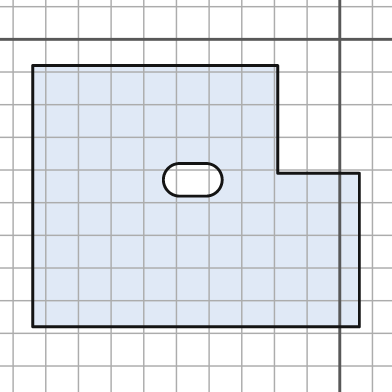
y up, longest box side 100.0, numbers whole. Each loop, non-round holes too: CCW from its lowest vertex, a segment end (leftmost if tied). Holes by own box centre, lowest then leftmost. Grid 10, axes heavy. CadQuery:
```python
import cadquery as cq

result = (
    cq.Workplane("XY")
    .moveTo(-94.0, -88.0)
    .lineTo(6.0, -88.0)
    .lineTo(6.0, -41.0)
    .lineTo(-19.0, -41.0)
    .lineTo(-19.0, -8.0)
    .lineTo(-94.0, -8.0)
    .close()
    .moveTo(-49.0, -48.0)
    .lineTo(-41.0, -48.0)
    .threePointArc((-36.0, -43.0), (-41.0, -38.0))
    .lineTo(-49.0, -38.0)
    .threePointArc((-54.0, -43.0), (-49.0, -48.0))
    .close()
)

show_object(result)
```